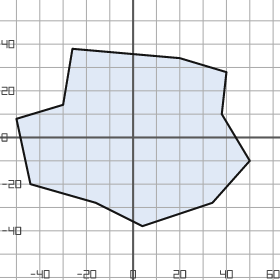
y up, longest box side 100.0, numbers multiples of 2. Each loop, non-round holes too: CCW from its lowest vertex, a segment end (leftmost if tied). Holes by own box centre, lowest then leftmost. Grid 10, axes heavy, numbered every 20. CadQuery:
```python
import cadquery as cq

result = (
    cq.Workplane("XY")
    .moveTo(4.0, -38.0)
    .lineTo(34.0, -28.0)
    .lineTo(50.0, -10.0)
    .lineTo(38.0, 10.0)
    .lineTo(40.0, 28.0)
    .lineTo(20.0, 34.0)
    .lineTo(-26.0, 38.0)
    .lineTo(-30.0, 14.0)
    .lineTo(-50.0, 8.0)
    .lineTo(-44.0, -20.0)
    .lineTo(-16.0, -28.0)
    .close()
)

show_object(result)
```